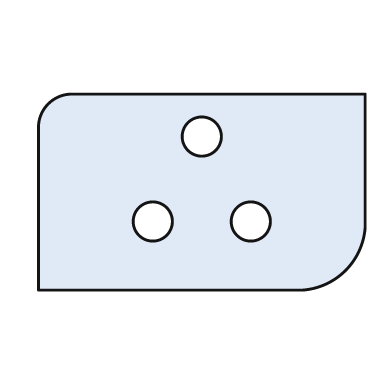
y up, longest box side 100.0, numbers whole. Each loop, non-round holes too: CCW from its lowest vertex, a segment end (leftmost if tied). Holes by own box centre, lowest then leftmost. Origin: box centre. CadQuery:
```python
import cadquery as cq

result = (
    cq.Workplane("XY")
    .moveTo(-50.0, -30.0)
    .lineTo(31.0, -30.0)
    .threePointArc((44.0, -24.0), (50.0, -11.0))
    .lineTo(50.0, 30.0)
    .lineTo(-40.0, 30.0)
    .threePointArc((-47.0, 27.0), (-50.0, 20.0))
    .close()
    .moveTo(-15.0, -9.0)
    .circle(6.0)
    .moveTo(15.0, -9.0)
    .circle(6.0)
    .moveTo(0.0, 17.0)
    .circle(6.0)
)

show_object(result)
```